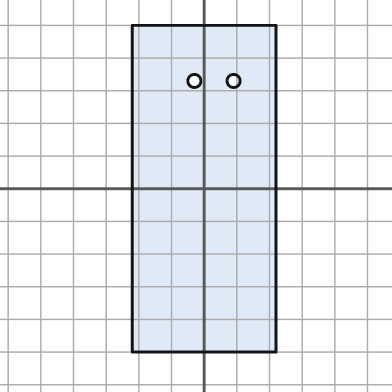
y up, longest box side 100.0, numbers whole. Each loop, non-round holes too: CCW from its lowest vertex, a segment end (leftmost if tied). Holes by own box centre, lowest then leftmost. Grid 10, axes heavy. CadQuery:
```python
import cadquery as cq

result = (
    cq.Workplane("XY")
    .moveTo(-22.0, -50.0)
    .lineTo(22.0, -50.0)
    .lineTo(22.0, 50.0)
    .lineTo(-22.0, 50.0)
    .close()
    .moveTo(-3.0, 33.0)
    .circle(2.0)
    .moveTo(9.0, 33.0)
    .circle(2.0)
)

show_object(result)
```